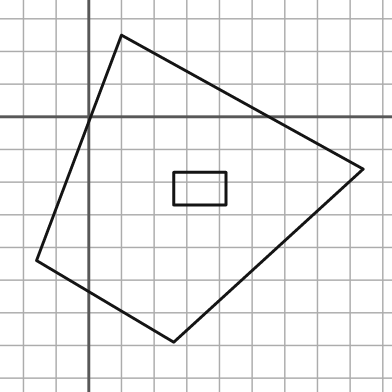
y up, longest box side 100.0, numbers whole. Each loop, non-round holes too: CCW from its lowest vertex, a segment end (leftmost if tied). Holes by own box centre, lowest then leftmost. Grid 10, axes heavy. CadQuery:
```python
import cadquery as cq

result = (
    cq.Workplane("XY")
    .moveTo(26.0, -69.0)
    .lineTo(84.0, -16.0)
    .lineTo(10.0, 25.0)
    .lineTo(-16.0, -44.0)
    .close()
    .moveTo(26.0, -27.0)
    .lineTo(42.0, -27.0)
    .lineTo(42.0, -17.0)
    .lineTo(26.0, -17.0)
    .close()
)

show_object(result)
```